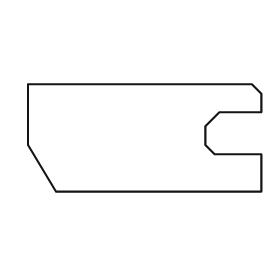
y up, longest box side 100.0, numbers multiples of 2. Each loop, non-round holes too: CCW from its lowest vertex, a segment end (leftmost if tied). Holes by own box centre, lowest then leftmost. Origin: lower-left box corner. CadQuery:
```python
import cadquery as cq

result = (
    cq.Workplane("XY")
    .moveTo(12.0, 0.0)
    .lineTo(100.0, 0.0)
    .lineTo(100.0, 16.0)
    .lineTo(80.0, 16.0)
    .lineTo(76.0, 20.0)
    .lineTo(76.0, 28.0)
    .lineTo(82.0, 34.0)
    .lineTo(100.0, 34.0)
    .lineTo(100.0, 42.0)
    .lineTo(96.0, 46.0)
    .lineTo(0.0, 46.0)
    .lineTo(0.0, 20.0)
    .close()
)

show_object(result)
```